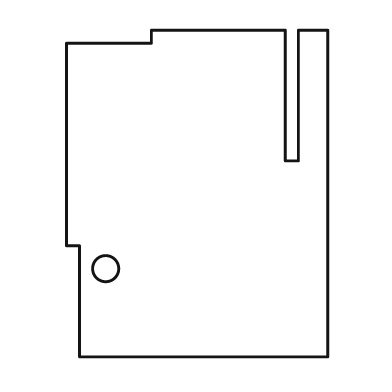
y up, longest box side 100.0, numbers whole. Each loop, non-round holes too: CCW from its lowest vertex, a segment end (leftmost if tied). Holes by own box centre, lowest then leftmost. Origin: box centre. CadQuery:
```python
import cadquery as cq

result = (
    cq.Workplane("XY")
    .moveTo(-36.0, -50.0)
    .lineTo(40.0, -50.0)
    .lineTo(40.0, 50.0)
    .lineTo(31.0, 50.0)
    .lineTo(31.0, 10.0)
    .lineTo(27.0, 10.0)
    .lineTo(27.0, 50.0)
    .lineTo(-14.0, 50.0)
    .lineTo(-14.0, 46.0)
    .lineTo(-40.0, 46.0)
    .lineTo(-40.0, -16.0)
    .lineTo(-36.0, -16.0)
    .close()
    .moveTo(-28.0, -23.0)
    .circle(4.0)
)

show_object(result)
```